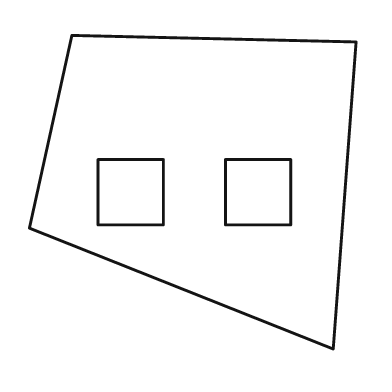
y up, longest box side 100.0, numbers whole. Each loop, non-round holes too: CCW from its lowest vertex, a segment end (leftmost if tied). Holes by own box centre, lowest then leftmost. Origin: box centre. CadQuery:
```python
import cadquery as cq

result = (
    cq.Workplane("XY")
    .moveTo(43.0, -48.0)
    .lineTo(50.0, 46.0)
    .lineTo(-37.0, 48.0)
    .lineTo(-50.0, -11.0)
    .close()
    .moveTo(-29.0, -10.0)
    .lineTo(-9.0, -10.0)
    .lineTo(-9.0, 10.0)
    .lineTo(-29.0, 10.0)
    .close()
    .moveTo(10.0, -10.0)
    .lineTo(30.0, -10.0)
    .lineTo(30.0, 10.0)
    .lineTo(10.0, 10.0)
    .close()
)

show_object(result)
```